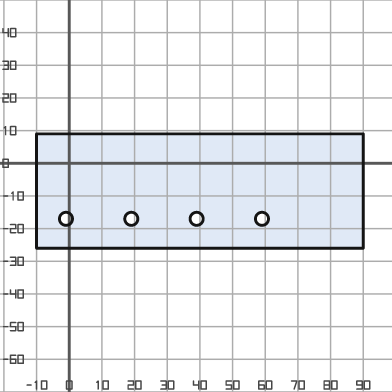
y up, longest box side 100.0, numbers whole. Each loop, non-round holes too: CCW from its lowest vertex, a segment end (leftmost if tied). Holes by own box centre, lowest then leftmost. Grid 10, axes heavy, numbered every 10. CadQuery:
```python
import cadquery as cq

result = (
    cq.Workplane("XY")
    .moveTo(-10.0, -26.0)
    .lineTo(90.0, -26.0)
    .lineTo(90.0, 9.0)
    .lineTo(-10.0, 9.0)
    .close()
    .moveTo(-1.0, -17.0)
    .circle(2.0)
    .moveTo(19.0, -17.0)
    .circle(2.0)
    .moveTo(39.0, -17.0)
    .circle(2.0)
    .moveTo(59.0, -17.0)
    .circle(2.0)
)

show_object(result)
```